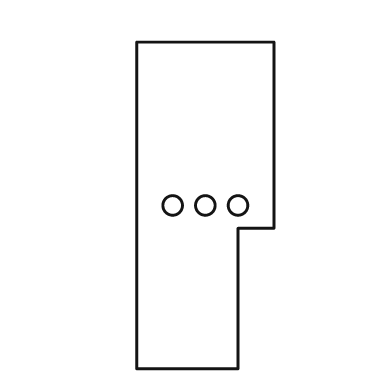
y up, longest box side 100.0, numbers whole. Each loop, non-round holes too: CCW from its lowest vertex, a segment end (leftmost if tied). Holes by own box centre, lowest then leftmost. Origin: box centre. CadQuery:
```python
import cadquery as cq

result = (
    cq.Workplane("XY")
    .moveTo(-21.0, -50.0)
    .lineTo(10.0, -50.0)
    .lineTo(10.0, -7.0)
    .lineTo(21.0, -7.0)
    .lineTo(21.0, 50.0)
    .lineTo(-21.0, 50.0)
    .close()
    .moveTo(-10.0, 0.0)
    .circle(3.0)
    .moveTo(0.0, 0.0)
    .circle(3.0)
    .moveTo(10.0, 0.0)
    .circle(3.0)
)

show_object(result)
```